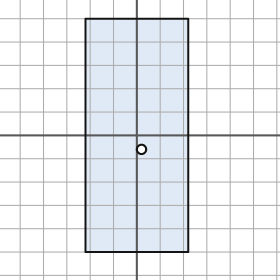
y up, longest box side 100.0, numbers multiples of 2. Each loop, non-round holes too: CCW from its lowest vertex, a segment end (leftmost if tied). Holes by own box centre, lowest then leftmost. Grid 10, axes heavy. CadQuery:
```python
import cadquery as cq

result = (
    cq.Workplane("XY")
    .moveTo(-22.0, -50.0)
    .lineTo(22.0, -50.0)
    .lineTo(22.0, 50.0)
    .lineTo(-22.0, 50.0)
    .close()
    .moveTo(2.0, -6.0)
    .circle(2.0)
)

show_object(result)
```